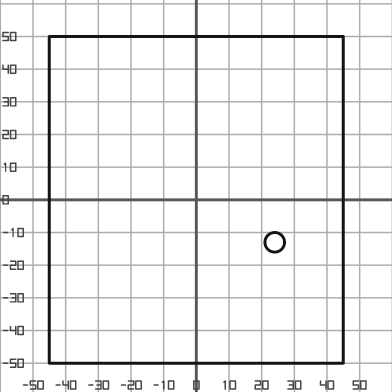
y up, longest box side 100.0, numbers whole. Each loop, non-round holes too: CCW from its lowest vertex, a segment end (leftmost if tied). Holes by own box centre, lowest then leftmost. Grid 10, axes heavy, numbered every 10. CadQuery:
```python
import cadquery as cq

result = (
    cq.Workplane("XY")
    .moveTo(-45.0, -50.0)
    .lineTo(45.0, -50.0)
    .lineTo(45.0, 50.0)
    .lineTo(-45.0, 50.0)
    .close()
    .moveTo(24.0, -13.0)
    .circle(3.0)
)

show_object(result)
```